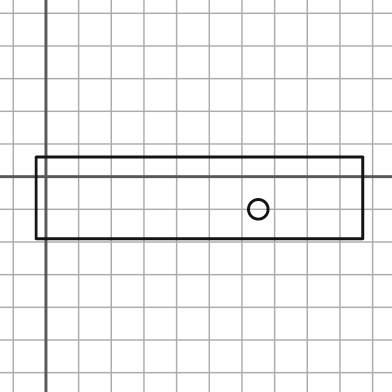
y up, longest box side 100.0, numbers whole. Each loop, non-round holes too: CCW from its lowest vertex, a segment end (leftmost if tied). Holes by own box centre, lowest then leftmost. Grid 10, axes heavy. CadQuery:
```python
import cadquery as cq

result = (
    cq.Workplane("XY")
    .moveTo(-3.0, -19.0)
    .lineTo(97.0, -19.0)
    .lineTo(97.0, 6.0)
    .lineTo(-3.0, 6.0)
    .close()
    .moveTo(65.0, -10.0)
    .circle(3.0)
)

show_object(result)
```